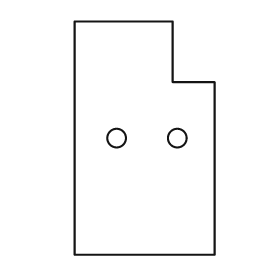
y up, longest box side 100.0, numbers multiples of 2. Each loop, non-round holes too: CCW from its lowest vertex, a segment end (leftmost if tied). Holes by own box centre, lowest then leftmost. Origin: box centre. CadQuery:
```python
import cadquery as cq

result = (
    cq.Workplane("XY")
    .moveTo(-30.0, -50.0)
    .lineTo(30.0, -50.0)
    .lineTo(30.0, 24.0)
    .lineTo(12.0, 24.0)
    .lineTo(12.0, 50.0)
    .lineTo(-30.0, 50.0)
    .close()
    .moveTo(-12.0, 0.0)
    .circle(4.0)
    .moveTo(14.0, 0.0)
    .circle(4.0)
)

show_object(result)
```